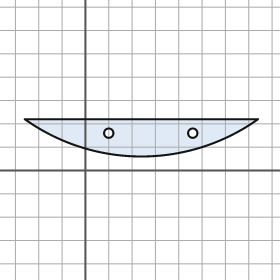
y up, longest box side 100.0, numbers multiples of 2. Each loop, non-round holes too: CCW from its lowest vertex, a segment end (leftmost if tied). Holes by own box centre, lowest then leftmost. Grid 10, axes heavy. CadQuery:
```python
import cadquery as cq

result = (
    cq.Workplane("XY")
    .moveTo(-26.0, 22.0)
    .threePointArc((24.0, 6.0), (74.0, 22.0))
    .close()
    .moveTo(10.0, 16.0)
    .circle(2.0)
    .moveTo(46.0, 16.0)
    .circle(2.0)
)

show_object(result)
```